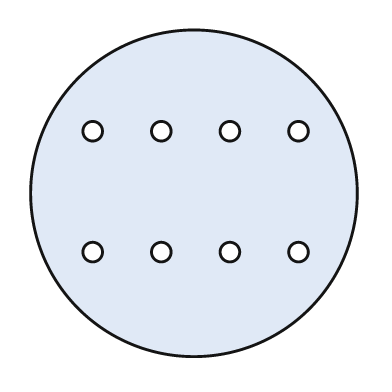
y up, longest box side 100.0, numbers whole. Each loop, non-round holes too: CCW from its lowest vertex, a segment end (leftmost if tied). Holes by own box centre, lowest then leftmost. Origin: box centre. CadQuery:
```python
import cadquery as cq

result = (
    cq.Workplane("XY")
    .moveTo(0.0, 0.0)
    .circle(50.0)
    .moveTo(-31.0, -18.0)
    .circle(3.0)
    .moveTo(-10.0, -18.0)
    .circle(3.0)
    .moveTo(11.0, -18.0)
    .circle(3.0)
    .moveTo(32.0, -18.0)
    .circle(3.0)
    .moveTo(-31.0, 19.0)
    .circle(3.0)
    .moveTo(-10.0, 19.0)
    .circle(3.0)
    .moveTo(11.0, 19.0)
    .circle(3.0)
    .moveTo(32.0, 19.0)
    .circle(3.0)
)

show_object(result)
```